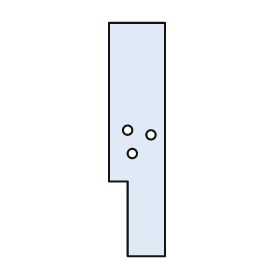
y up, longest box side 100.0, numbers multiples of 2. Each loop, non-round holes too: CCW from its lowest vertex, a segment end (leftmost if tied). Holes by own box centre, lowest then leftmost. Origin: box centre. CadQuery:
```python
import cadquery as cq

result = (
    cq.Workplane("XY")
    .moveTo(-4.0, -50.0)
    .lineTo(12.0, -50.0)
    .lineTo(12.0, 50.0)
    .lineTo(-12.0, 50.0)
    .lineTo(-12.0, -18.0)
    .lineTo(-4.0, -18.0)
    .close()
    .moveTo(-2.0, -6.0)
    .circle(2.0)
    .moveTo(6.0, 2.0)
    .circle(2.0)
    .moveTo(-4.0, 4.0)
    .circle(2.0)
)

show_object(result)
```